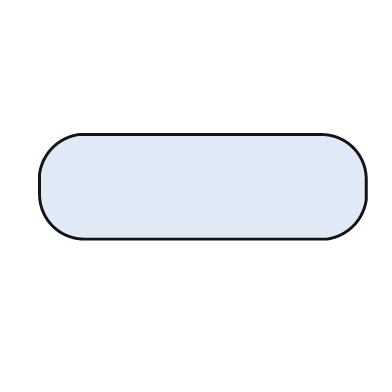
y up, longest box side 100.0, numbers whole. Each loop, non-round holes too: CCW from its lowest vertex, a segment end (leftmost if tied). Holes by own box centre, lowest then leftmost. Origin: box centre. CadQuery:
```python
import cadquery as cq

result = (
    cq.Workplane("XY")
    .moveTo(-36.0, -16.0)
    .lineTo(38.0, -16.0)
    .threePointArc((46.0, -12.0), (50.0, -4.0))
    .lineTo(50.0, 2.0)
    .threePointArc((46.0, 12.0), (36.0, 16.0))
    .lineTo(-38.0, 16.0)
    .threePointArc((-46.0, 12.0), (-50.0, 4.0))
    .lineTo(-50.0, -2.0)
    .threePointArc((-46.0, -12.0), (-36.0, -16.0))
    .close()
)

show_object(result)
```